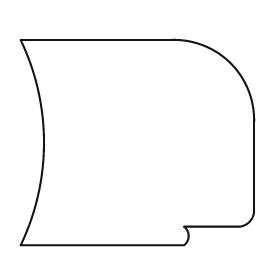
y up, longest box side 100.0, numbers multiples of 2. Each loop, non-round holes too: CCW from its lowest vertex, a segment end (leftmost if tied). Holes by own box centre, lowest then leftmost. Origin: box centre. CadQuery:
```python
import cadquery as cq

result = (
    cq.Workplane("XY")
    .moveTo(-50.0, -44.0)
    .lineTo(20.0, -44.0)
    .threePointArc((22.0, -40.0), (20.0, -36.0))
    .lineTo(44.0, -36.0)
    .threePointArc((48.0, -34.0), (50.0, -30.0))
    .lineTo(50.0, 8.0)
    .threePointArc((40.0, 34.0), (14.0, 44.0))
    .lineTo(-50.0, 44.0)
    .threePointArc((-40.0, 0.0), (-50.0, -44.0))
    .close()
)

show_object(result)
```